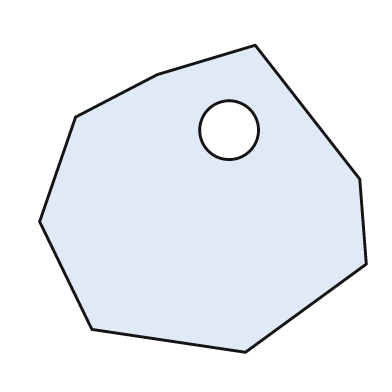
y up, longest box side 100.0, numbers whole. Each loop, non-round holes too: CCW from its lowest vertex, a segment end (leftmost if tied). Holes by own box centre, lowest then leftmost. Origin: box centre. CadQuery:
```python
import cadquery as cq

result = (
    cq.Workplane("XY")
    .moveTo(13.0, -47.0)
    .lineTo(50.0, -20.0)
    .lineTo(48.0, 6.0)
    .lineTo(16.0, 47.0)
    .lineTo(-14.0, 38.0)
    .lineTo(-39.0, 25.0)
    .lineTo(-50.0, -7.0)
    .lineTo(-34.0, -40.0)
    .close()
    .moveTo(8.0, 21.0)
    .circle(9.0)
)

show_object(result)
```